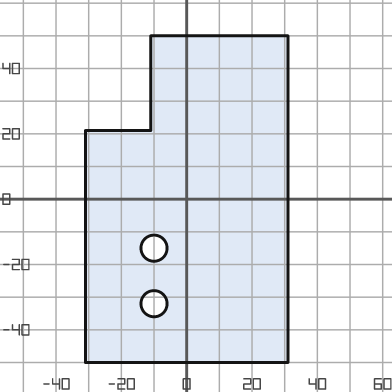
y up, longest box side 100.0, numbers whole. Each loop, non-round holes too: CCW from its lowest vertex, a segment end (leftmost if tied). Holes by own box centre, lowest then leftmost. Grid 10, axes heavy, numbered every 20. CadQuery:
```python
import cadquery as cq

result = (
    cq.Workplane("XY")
    .moveTo(-31.0, -50.0)
    .lineTo(31.0, -50.0)
    .lineTo(31.0, 50.0)
    .lineTo(-11.0, 50.0)
    .lineTo(-11.0, 21.0)
    .lineTo(-31.0, 21.0)
    .close()
    .moveTo(-10.0, -32.0)
    .circle(4.0)
    .moveTo(-10.0, -15.0)
    .circle(4.0)
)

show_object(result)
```